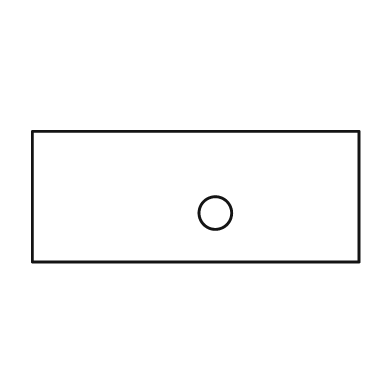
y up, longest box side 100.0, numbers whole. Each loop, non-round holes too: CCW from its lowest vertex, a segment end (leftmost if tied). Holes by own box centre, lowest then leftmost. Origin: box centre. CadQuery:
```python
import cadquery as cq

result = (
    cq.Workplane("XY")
    .moveTo(-50.0, -20.0)
    .lineTo(50.0, -20.0)
    .lineTo(50.0, 20.0)
    .lineTo(-50.0, 20.0)
    .close()
    .moveTo(6.0, -5.0)
    .circle(5.0)
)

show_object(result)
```